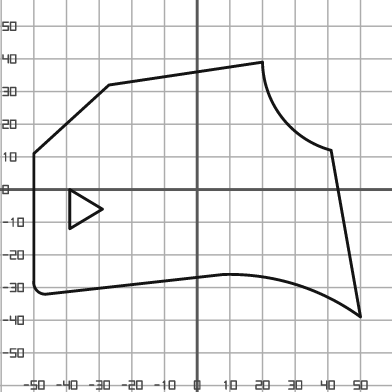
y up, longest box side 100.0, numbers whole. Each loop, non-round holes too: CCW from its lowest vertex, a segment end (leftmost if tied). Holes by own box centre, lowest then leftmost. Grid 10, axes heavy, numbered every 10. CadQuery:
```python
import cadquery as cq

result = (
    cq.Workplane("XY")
    .moveTo(50.0, -39.0)
    .lineTo(41.0, 12.0)
    .threePointArc((26.0, 22.0), (20.0, 39.0))
    .lineTo(-27.0, 32.0)
    .lineTo(-50.0, 11.0)
    .lineTo(-50.0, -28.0)
    .threePointArc((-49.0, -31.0), (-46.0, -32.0))
    .lineTo(8.0, -26.0)
    .threePointArc((30.0, -29.0), (50.0, -39.0))
    .close()
    .moveTo(-39.0, -12.0)
    .lineTo(-29.0, -6.0)
    .lineTo(-39.0, 0.0)
    .close()
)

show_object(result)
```